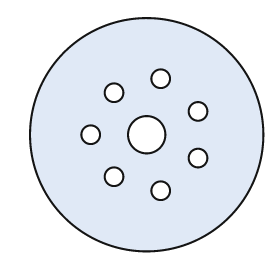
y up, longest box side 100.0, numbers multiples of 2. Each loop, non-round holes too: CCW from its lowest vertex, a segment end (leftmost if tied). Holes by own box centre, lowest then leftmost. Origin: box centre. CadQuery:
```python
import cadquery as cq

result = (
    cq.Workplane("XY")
    .moveTo(0.0, 0.0)
    .circle(50.0)
    .moveTo(6.0, -24.0)
    .circle(4.0)
    .moveTo(-14.0, -18.0)
    .circle(4.0)
    .moveTo(22.0, -10.0)
    .circle(4.0)
    .moveTo(-24.0, 0.0)
    .circle(4.0)
    .moveTo(0.0, 0.0)
    .circle(8.0)
    .moveTo(22.0, 10.0)
    .circle(4.0)
    .moveTo(-14.0, 18.0)
    .circle(4.0)
    .moveTo(6.0, 24.0)
    .circle(4.0)
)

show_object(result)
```